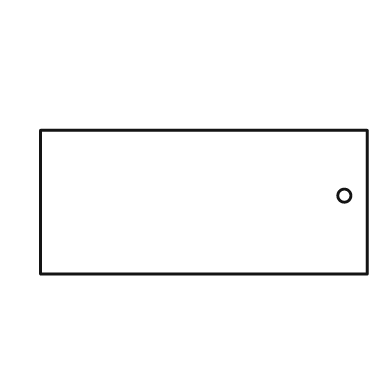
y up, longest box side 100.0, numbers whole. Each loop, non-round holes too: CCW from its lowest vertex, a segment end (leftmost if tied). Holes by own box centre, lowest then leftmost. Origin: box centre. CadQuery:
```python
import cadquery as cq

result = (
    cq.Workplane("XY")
    .moveTo(-50.0, -22.0)
    .lineTo(50.0, -22.0)
    .lineTo(50.0, 22.0)
    .lineTo(-50.0, 22.0)
    .close()
    .moveTo(43.0, 2.0)
    .circle(2.0)
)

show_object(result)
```